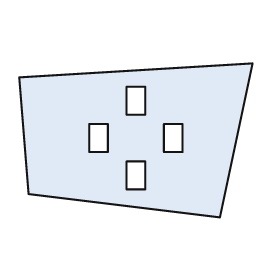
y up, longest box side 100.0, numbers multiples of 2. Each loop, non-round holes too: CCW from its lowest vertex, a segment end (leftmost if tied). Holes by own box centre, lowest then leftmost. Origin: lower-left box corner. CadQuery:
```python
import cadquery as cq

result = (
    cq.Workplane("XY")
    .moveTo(86.0, 0.0)
    .lineTo(100.0, 66.0)
    .lineTo(0.0, 60.0)
    .lineTo(4.0, 10.0)
    .close()
    .moveTo(46.0, 12.0)
    .lineTo(54.0, 12.0)
    .lineTo(54.0, 24.0)
    .lineTo(46.0, 24.0)
    .close()
    .moveTo(30.0, 28.0)
    .lineTo(38.0, 28.0)
    .lineTo(38.0, 40.0)
    .lineTo(30.0, 40.0)
    .close()
    .moveTo(62.0, 28.0)
    .lineTo(70.0, 28.0)
    .lineTo(70.0, 40.0)
    .lineTo(62.0, 40.0)
    .close()
    .moveTo(46.0, 44.0)
    .lineTo(54.0, 44.0)
    .lineTo(54.0, 56.0)
    .lineTo(46.0, 56.0)
    .close()
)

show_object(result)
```